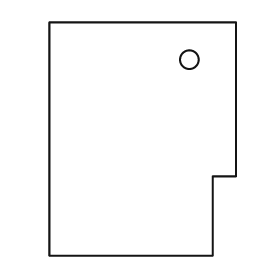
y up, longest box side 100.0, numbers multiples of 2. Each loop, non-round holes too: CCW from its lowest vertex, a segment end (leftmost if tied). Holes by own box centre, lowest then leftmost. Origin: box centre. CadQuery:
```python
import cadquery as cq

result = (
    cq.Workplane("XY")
    .moveTo(-40.0, -50.0)
    .lineTo(30.0, -50.0)
    .lineTo(30.0, -16.0)
    .lineTo(40.0, -16.0)
    .lineTo(40.0, 50.0)
    .lineTo(-40.0, 50.0)
    .close()
    .moveTo(20.0, 34.0)
    .circle(4.0)
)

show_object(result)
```